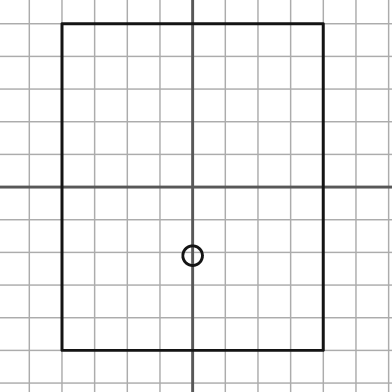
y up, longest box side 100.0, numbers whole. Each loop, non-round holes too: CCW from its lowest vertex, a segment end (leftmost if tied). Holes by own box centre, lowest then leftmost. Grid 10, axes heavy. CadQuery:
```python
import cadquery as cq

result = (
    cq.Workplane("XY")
    .moveTo(-40.0, -50.0)
    .lineTo(40.0, -50.0)
    .lineTo(40.0, 50.0)
    .lineTo(-40.0, 50.0)
    .close()
    .moveTo(0.0, -21.0)
    .circle(3.0)
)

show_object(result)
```